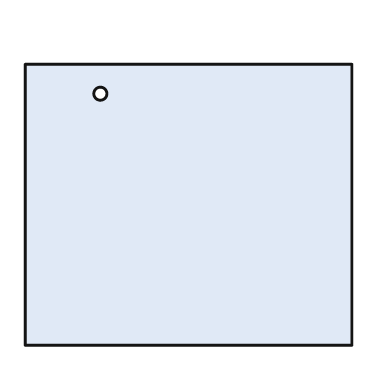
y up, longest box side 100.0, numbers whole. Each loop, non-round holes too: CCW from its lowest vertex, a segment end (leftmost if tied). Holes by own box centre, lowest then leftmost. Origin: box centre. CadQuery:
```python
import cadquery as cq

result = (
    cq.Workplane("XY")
    .moveTo(-50.0, -43.0)
    .lineTo(50.0, -43.0)
    .lineTo(50.0, 43.0)
    .lineTo(-50.0, 43.0)
    .close()
    .moveTo(-27.0, 34.0)
    .circle(2.0)
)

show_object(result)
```